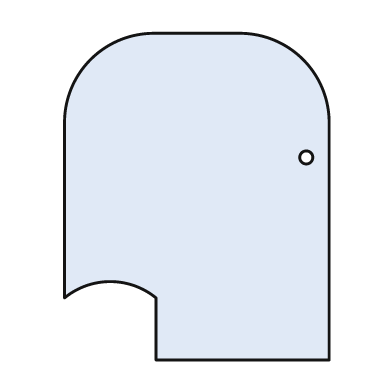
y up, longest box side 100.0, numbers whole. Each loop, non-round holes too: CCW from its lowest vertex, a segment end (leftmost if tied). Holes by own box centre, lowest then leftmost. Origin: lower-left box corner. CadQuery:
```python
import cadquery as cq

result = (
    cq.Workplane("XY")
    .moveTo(28.0, 0.0)
    .lineTo(81.0, 0.0)
    .lineTo(81.0, 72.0)
    .threePointArc((73.0, 92.0), (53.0, 100.0))
    .lineTo(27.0, 100.0)
    .threePointArc((8.0, 92.0), (0.0, 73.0))
    .lineTo(0.0, 19.0)
    .threePointArc((14.0, 24.0), (28.0, 19.0))
    .close()
    .moveTo(74.0, 62.0)
    .circle(2.0)
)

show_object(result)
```